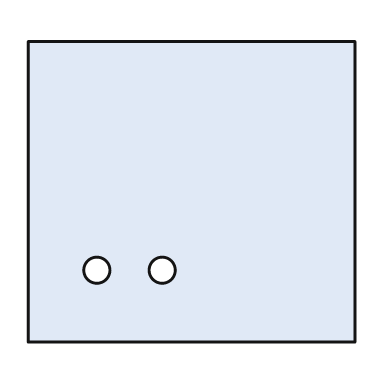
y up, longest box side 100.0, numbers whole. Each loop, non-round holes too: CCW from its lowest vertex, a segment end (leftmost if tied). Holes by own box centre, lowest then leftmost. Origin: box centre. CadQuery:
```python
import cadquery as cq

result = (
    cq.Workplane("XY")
    .moveTo(-50.0, -46.0)
    .lineTo(50.0, -46.0)
    .lineTo(50.0, 46.0)
    .lineTo(-50.0, 46.0)
    .close()
    .moveTo(-29.0, -24.0)
    .circle(4.0)
    .moveTo(-9.0, -24.0)
    .circle(4.0)
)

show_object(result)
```